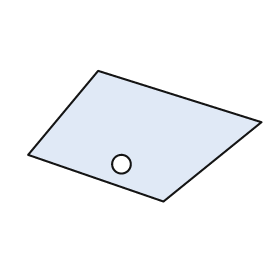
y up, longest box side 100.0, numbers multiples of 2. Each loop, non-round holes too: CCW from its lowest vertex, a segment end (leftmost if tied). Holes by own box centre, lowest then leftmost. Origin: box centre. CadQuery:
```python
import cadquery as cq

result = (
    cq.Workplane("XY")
    .moveTo(8.0, -28.0)
    .lineTo(50.0, 6.0)
    .lineTo(-20.0, 28.0)
    .lineTo(-50.0, -8.0)
    .close()
    .moveTo(-10.0, -12.0)
    .circle(4.0)
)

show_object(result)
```